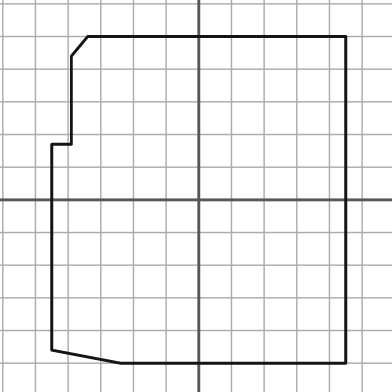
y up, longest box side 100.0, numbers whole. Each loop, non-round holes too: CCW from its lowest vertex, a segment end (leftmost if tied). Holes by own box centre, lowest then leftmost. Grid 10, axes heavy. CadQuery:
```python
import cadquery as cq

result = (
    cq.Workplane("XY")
    .moveTo(-24.0, -50.0)
    .lineTo(45.0, -50.0)
    .lineTo(45.0, 50.0)
    .lineTo(-34.0, 50.0)
    .lineTo(-39.0, 44.0)
    .lineTo(-39.0, 17.0)
    .lineTo(-45.0, 17.0)
    .lineTo(-45.0, -46.0)
    .close()
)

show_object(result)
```